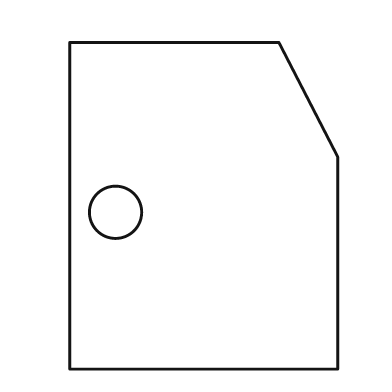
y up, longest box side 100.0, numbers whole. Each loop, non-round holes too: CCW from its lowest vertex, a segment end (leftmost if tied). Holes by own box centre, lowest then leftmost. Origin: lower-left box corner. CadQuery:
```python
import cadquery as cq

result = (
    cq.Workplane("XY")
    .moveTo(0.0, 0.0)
    .lineTo(82.0, 0.0)
    .lineTo(82.0, 65.0)
    .lineTo(64.0, 100.0)
    .lineTo(0.0, 100.0)
    .close()
    .moveTo(14.0, 48.0)
    .circle(8.0)
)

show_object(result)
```